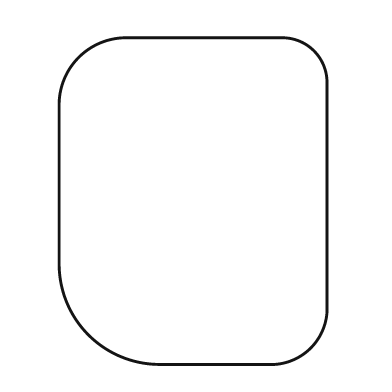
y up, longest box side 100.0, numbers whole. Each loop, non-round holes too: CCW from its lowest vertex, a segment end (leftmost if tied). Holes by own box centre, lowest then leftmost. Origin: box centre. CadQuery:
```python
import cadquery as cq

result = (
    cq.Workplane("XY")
    .moveTo(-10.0, -50.0)
    .lineTo(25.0, -50.0)
    .threePointArc((36.0, -45.0), (41.0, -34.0))
    .lineTo(41.0, 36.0)
    .threePointArc((37.0, 46.0), (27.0, 50.0))
    .lineTo(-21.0, 50.0)
    .threePointArc((-35.0, 44.0), (-41.0, 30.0))
    .lineTo(-41.0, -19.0)
    .threePointArc((-32.0, -41.0), (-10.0, -50.0))
    .close()
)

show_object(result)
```